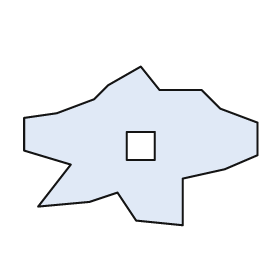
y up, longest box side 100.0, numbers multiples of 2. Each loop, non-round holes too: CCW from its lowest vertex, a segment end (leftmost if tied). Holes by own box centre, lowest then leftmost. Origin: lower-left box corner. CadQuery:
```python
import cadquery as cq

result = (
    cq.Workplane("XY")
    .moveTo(68.0, 0.0)
    .lineTo(68.0, 20.0)
    .lineTo(86.0, 24.0)
    .lineTo(100.0, 30.0)
    .lineTo(100.0, 44.0)
    .lineTo(84.0, 50.0)
    .lineTo(76.0, 58.0)
    .lineTo(58.0, 58.0)
    .lineTo(50.0, 68.0)
    .lineTo(36.0, 60.0)
    .lineTo(30.0, 54.0)
    .lineTo(14.0, 48.0)
    .lineTo(0.0, 46.0)
    .lineTo(0.0, 32.0)
    .lineTo(20.0, 26.0)
    .lineTo(6.0, 8.0)
    .lineTo(28.0, 10.0)
    .lineTo(40.0, 14.0)
    .lineTo(48.0, 2.0)
    .close()
    .moveTo(44.0, 28.0)
    .lineTo(56.0, 28.0)
    .lineTo(56.0, 40.0)
    .lineTo(44.0, 40.0)
    .close()
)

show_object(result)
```